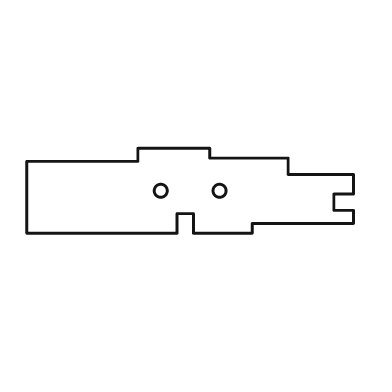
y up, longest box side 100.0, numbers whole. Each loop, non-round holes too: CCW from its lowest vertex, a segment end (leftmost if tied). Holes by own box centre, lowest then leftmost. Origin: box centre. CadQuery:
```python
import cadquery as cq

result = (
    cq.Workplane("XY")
    .moveTo(-50.0, -13.0)
    .lineTo(-4.0, -13.0)
    .lineTo(-4.0, -7.0)
    .lineTo(1.0, -7.0)
    .lineTo(1.0, -13.0)
    .lineTo(19.0, -13.0)
    .lineTo(19.0, -10.0)
    .lineTo(50.0, -10.0)
    .lineTo(50.0, -6.0)
    .lineTo(44.0, -6.0)
    .lineTo(44.0, -1.0)
    .lineTo(50.0, -1.0)
    .lineTo(50.0, 5.0)
    .lineTo(30.0, 5.0)
    .lineTo(30.0, 10.0)
    .lineTo(6.0, 10.0)
    .lineTo(6.0, 13.0)
    .lineTo(-16.0, 13.0)
    .lineTo(-16.0, 9.0)
    .lineTo(-50.0, 9.0)
    .close()
    .moveTo(-9.0, 0.0)
    .circle(2.0)
    .moveTo(9.0, 0.0)
    .circle(2.0)
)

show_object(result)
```